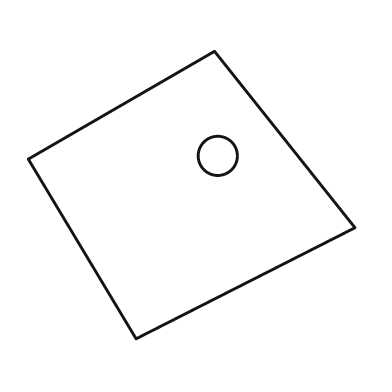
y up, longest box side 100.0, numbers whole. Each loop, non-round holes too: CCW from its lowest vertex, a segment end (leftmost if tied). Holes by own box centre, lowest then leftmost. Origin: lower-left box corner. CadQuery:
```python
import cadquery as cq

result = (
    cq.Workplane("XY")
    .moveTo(33.0, 0.0)
    .lineTo(100.0, 34.0)
    .lineTo(57.0, 88.0)
    .lineTo(0.0, 55.0)
    .close()
    .moveTo(58.0, 56.0)
    .circle(6.0)
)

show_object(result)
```